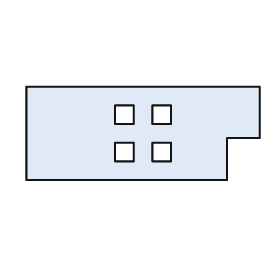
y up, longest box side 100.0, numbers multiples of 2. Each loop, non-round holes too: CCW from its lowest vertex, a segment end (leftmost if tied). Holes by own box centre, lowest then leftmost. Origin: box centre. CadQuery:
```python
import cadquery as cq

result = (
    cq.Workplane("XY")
    .moveTo(-50.0, -20.0)
    .lineTo(36.0, -20.0)
    .lineTo(36.0, -2.0)
    .lineTo(50.0, -2.0)
    .lineTo(50.0, 20.0)
    .lineTo(-50.0, 20.0)
    .close()
    .moveTo(-12.0, -12.0)
    .lineTo(-4.0, -12.0)
    .lineTo(-4.0, -4.0)
    .lineTo(-12.0, -4.0)
    .close()
    .moveTo(4.0, -12.0)
    .lineTo(12.0, -12.0)
    .lineTo(12.0, -4.0)
    .lineTo(4.0, -4.0)
    .close()
    .moveTo(-12.0, 4.0)
    .lineTo(-4.0, 4.0)
    .lineTo(-4.0, 12.0)
    .lineTo(-12.0, 12.0)
    .close()
    .moveTo(4.0, 4.0)
    .lineTo(12.0, 4.0)
    .lineTo(12.0, 12.0)
    .lineTo(4.0, 12.0)
    .close()
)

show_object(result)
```